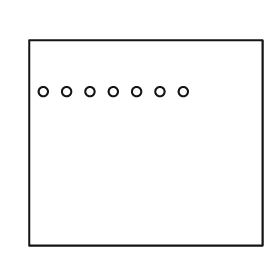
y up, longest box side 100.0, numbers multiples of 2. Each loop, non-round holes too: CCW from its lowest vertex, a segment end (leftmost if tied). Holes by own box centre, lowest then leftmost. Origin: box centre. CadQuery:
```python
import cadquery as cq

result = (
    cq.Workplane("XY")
    .moveTo(-50.0, -44.0)
    .lineTo(50.0, -44.0)
    .lineTo(50.0, 44.0)
    .lineTo(-50.0, 44.0)
    .close()
    .moveTo(-44.0, 22.0)
    .circle(2.0)
    .moveTo(-34.0, 22.0)
    .circle(2.0)
    .moveTo(-24.0, 22.0)
    .circle(2.0)
    .moveTo(-14.0, 22.0)
    .circle(2.0)
    .moveTo(-4.0, 22.0)
    .circle(2.0)
    .moveTo(6.0, 22.0)
    .circle(2.0)
    .moveTo(16.0, 22.0)
    .circle(2.0)
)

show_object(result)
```